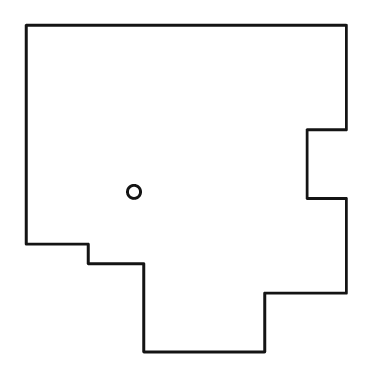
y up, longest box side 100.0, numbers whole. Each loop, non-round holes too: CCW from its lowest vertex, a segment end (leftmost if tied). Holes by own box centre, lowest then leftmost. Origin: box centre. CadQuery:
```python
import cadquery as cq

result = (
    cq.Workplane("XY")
    .moveTo(-13.0, -50.0)
    .lineTo(24.0, -50.0)
    .lineTo(24.0, -32.0)
    .lineTo(49.0, -32.0)
    .lineTo(49.0, -3.0)
    .lineTo(37.0, -3.0)
    .lineTo(37.0, 18.0)
    .lineTo(49.0, 18.0)
    .lineTo(49.0, 50.0)
    .lineTo(-49.0, 50.0)
    .lineTo(-49.0, -17.0)
    .lineTo(-30.0, -17.0)
    .lineTo(-30.0, -23.0)
    .lineTo(-13.0, -23.0)
    .close()
    .moveTo(-16.0, -1.0)
    .circle(2.0)
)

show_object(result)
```